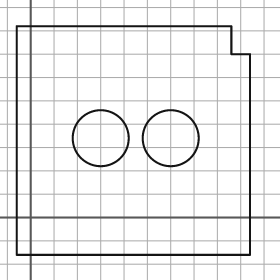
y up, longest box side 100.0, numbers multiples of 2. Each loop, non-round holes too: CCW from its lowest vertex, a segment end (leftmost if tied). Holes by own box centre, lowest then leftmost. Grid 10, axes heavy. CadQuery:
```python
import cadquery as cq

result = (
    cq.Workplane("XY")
    .moveTo(-6.0, -16.0)
    .lineTo(94.0, -16.0)
    .lineTo(94.0, 70.0)
    .lineTo(86.0, 70.0)
    .lineTo(86.0, 82.0)
    .lineTo(-6.0, 82.0)
    .close()
    .moveTo(30.0, 34.0)
    .circle(12.0)
    .moveTo(60.0, 34.0)
    .circle(12.0)
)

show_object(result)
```